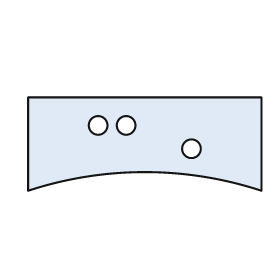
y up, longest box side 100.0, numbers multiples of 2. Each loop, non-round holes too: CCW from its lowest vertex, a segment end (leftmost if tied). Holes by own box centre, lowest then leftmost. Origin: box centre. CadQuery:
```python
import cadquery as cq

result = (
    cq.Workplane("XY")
    .moveTo(-50.0, -20.0)
    .threePointArc((0.0, -12.0), (50.0, -20.0))
    .lineTo(50.0, 20.0)
    .lineTo(-50.0, 20.0)
    .close()
    .moveTo(20.0, -2.0)
    .circle(4.0)
    .moveTo(-20.0, 8.0)
    .circle(4.0)
    .moveTo(-8.0, 8.0)
    .circle(4.0)
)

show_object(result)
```